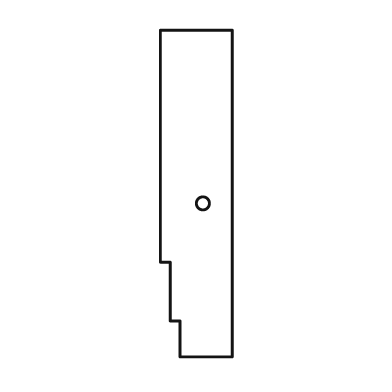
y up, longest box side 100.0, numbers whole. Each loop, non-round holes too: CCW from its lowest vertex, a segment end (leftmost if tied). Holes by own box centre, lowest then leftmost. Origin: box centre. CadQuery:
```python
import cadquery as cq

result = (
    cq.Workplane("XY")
    .moveTo(-5.0, -50.0)
    .lineTo(11.0, -50.0)
    .lineTo(11.0, 50.0)
    .lineTo(-11.0, 50.0)
    .lineTo(-11.0, -21.0)
    .lineTo(-8.0, -21.0)
    .lineTo(-8.0, -39.0)
    .lineTo(-5.0, -39.0)
    .close()
    .moveTo(2.0, -3.0)
    .circle(2.0)
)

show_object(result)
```